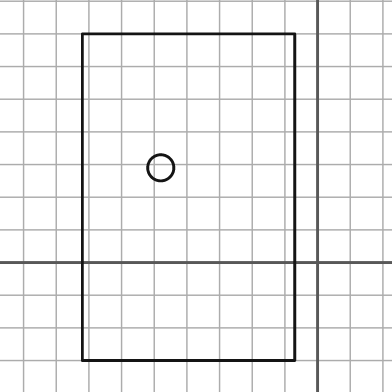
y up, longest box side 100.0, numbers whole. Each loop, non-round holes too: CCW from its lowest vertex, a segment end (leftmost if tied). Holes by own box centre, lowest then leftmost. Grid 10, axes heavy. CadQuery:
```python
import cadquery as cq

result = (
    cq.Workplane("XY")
    .moveTo(-72.0, -30.0)
    .lineTo(-7.0, -30.0)
    .lineTo(-7.0, 70.0)
    .lineTo(-72.0, 70.0)
    .close()
    .moveTo(-48.0, 29.0)
    .circle(4.0)
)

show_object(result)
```